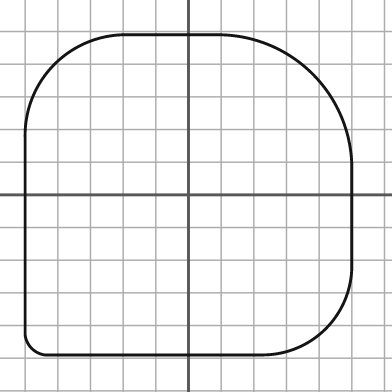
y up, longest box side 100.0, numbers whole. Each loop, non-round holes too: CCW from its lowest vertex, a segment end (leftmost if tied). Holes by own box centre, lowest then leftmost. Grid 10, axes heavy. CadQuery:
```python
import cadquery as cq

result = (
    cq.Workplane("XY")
    .moveTo(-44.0, -49.0)
    .lineTo(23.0, -49.0)
    .threePointArc((42.0, -41.0), (50.0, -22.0))
    .lineTo(50.0, 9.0)
    .threePointArc((38.0, 37.0), (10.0, 49.0))
    .lineTo(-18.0, 49.0)
    .threePointArc((-41.0, 40.0), (-50.0, 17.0))
    .lineTo(-50.0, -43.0)
    .threePointArc((-48.0, -47.0), (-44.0, -49.0))
    .close()
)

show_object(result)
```